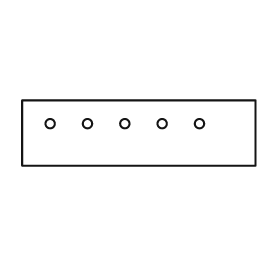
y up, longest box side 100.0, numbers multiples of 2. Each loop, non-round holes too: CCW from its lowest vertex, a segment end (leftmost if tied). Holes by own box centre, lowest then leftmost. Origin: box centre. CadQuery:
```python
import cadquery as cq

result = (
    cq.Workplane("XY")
    .moveTo(-50.0, -14.0)
    .lineTo(50.0, -14.0)
    .lineTo(50.0, 14.0)
    .lineTo(-50.0, 14.0)
    .close()
    .moveTo(-38.0, 4.0)
    .circle(2.0)
    .moveTo(-22.0, 4.0)
    .circle(2.0)
    .moveTo(-6.0, 4.0)
    .circle(2.0)
    .moveTo(10.0, 4.0)
    .circle(2.0)
    .moveTo(26.0, 4.0)
    .circle(2.0)
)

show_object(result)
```